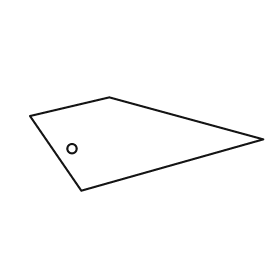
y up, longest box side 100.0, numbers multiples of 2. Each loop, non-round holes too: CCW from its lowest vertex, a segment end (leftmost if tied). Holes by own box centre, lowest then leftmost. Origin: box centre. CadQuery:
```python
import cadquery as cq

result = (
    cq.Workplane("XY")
    .moveTo(-28.0, -20.0)
    .lineTo(50.0, 2.0)
    .lineTo(-16.0, 20.0)
    .lineTo(-50.0, 12.0)
    .close()
    .moveTo(-32.0, -2.0)
    .circle(2.0)
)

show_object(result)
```